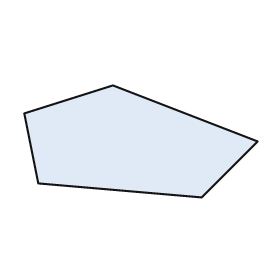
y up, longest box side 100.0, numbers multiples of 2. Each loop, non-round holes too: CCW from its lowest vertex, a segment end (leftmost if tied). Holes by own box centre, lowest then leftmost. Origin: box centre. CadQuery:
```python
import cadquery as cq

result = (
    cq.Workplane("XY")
    .moveTo(26.0, -24.0)
    .lineTo(50.0, 0.0)
    .lineTo(-12.0, 24.0)
    .lineTo(-50.0, 12.0)
    .lineTo(-44.0, -18.0)
    .close()
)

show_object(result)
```